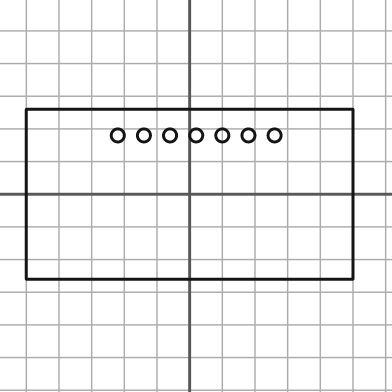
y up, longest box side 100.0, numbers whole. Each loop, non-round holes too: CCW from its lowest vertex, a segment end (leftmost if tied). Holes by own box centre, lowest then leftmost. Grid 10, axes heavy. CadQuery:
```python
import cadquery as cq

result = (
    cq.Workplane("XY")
    .moveTo(-50.0, -26.0)
    .lineTo(50.0, -26.0)
    .lineTo(50.0, 26.0)
    .lineTo(-50.0, 26.0)
    .close()
    .moveTo(-22.0, 18.0)
    .circle(2.0)
    .moveTo(-14.0, 18.0)
    .circle(2.0)
    .moveTo(-6.0, 18.0)
    .circle(2.0)
    .moveTo(2.0, 18.0)
    .circle(2.0)
    .moveTo(10.0, 18.0)
    .circle(2.0)
    .moveTo(18.0, 18.0)
    .circle(2.0)
    .moveTo(26.0, 18.0)
    .circle(2.0)
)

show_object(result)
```